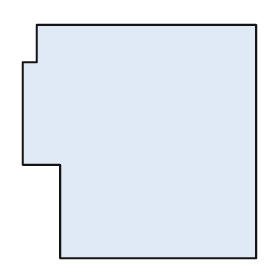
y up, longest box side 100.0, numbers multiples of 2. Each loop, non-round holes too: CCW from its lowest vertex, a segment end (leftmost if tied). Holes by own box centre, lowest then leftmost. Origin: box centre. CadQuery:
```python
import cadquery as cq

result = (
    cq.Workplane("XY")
    .moveTo(-34.0, -50.0)
    .lineTo(50.0, -50.0)
    .lineTo(50.0, 50.0)
    .lineTo(-44.0, 50.0)
    .lineTo(-44.0, 34.0)
    .lineTo(-50.0, 34.0)
    .lineTo(-50.0, -10.0)
    .lineTo(-34.0, -10.0)
    .close()
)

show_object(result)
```